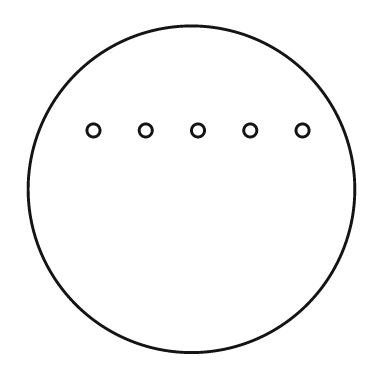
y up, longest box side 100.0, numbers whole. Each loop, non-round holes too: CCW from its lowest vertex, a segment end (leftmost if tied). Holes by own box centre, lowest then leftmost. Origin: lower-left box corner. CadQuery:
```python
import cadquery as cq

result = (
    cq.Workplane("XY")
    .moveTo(50.0, 50.0)
    .circle(50.0)
    .moveTo(20.0, 68.0)
    .circle(2.0)
    .moveTo(36.0, 68.0)
    .circle(2.0)
    .moveTo(52.0, 68.0)
    .circle(2.0)
    .moveTo(68.0, 68.0)
    .circle(2.0)
    .moveTo(84.0, 68.0)
    .circle(2.0)
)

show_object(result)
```